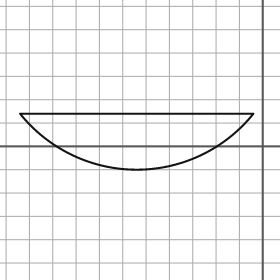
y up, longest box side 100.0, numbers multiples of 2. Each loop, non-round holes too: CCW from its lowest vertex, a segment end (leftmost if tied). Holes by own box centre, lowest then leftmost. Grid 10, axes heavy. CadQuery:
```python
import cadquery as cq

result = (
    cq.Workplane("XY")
    .moveTo(-104.0, 14.0)
    .threePointArc((-54.0, -10.0), (-4.0, 14.0))
    .close()
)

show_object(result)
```